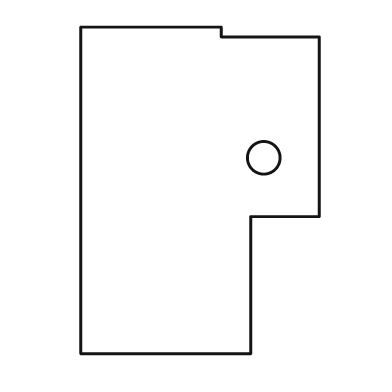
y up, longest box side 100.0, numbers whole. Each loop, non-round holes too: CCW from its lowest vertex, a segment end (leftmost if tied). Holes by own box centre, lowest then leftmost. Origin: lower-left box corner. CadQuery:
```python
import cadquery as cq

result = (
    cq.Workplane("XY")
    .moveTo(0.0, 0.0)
    .lineTo(52.0, 0.0)
    .lineTo(52.0, 42.0)
    .lineTo(73.0, 42.0)
    .lineTo(73.0, 97.0)
    .lineTo(43.0, 97.0)
    .lineTo(43.0, 100.0)
    .lineTo(0.0, 100.0)
    .close()
    .moveTo(56.0, 60.0)
    .circle(5.0)
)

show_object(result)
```